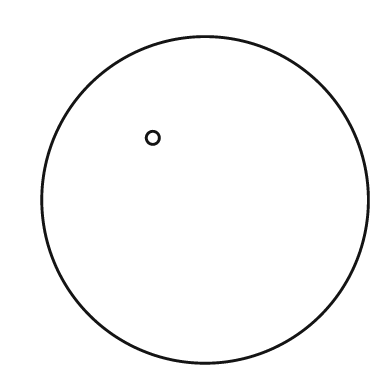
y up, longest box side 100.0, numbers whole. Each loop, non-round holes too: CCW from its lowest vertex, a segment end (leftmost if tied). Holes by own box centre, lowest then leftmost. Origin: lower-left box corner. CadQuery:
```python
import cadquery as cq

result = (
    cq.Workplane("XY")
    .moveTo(50.0, 50.0)
    .circle(50.0)
    .moveTo(34.0, 69.0)
    .circle(2.0)
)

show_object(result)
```